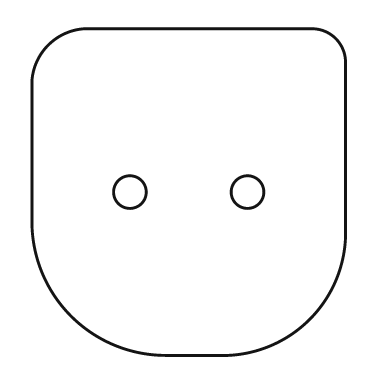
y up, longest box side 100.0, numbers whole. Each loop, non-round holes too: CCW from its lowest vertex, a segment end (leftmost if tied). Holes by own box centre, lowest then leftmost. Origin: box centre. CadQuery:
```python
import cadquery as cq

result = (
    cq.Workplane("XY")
    .moveTo(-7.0, -50.0)
    .lineTo(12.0, -50.0)
    .threePointArc((37.0, -39.0), (48.0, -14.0))
    .lineTo(48.0, 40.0)
    .threePointArc((45.0, 47.0), (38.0, 50.0))
    .lineTo(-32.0, 50.0)
    .threePointArc((-43.0, 45.0), (-48.0, 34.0))
    .lineTo(-48.0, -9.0)
    .threePointArc((-36.0, -38.0), (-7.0, -50.0))
    .close()
    .moveTo(-18.0, 0.0)
    .circle(5.0)
    .moveTo(18.0, 0.0)
    .circle(5.0)
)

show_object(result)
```